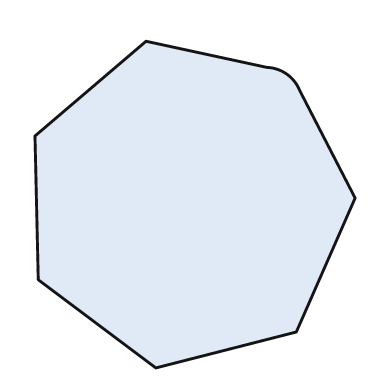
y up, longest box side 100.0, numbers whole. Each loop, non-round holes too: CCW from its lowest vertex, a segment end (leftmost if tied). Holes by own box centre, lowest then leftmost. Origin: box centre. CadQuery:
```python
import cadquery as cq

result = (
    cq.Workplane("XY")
    .moveTo(-12.0, -50.0)
    .lineTo(31.0, -39.0)
    .lineTo(49.0, 2.0)
    .lineTo(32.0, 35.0)
    .threePointArc((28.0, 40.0), (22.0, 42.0))
    .lineTo(-15.0, 50.0)
    .lineTo(-49.0, 21.0)
    .lineTo(-48.0, -23.0)
    .close()
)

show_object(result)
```